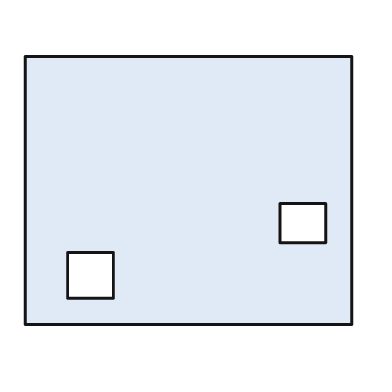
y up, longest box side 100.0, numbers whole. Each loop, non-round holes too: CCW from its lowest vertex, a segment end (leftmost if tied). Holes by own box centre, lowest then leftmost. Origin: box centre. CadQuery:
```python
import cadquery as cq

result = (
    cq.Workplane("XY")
    .moveTo(-50.0, -41.0)
    .lineTo(50.0, -41.0)
    .lineTo(50.0, 41.0)
    .lineTo(-50.0, 41.0)
    .close()
    .moveTo(-37.0, -33.0)
    .lineTo(-23.0, -33.0)
    .lineTo(-23.0, -19.0)
    .lineTo(-37.0, -19.0)
    .close()
    .moveTo(28.0, -16.0)
    .lineTo(42.0, -16.0)
    .lineTo(42.0, -4.0)
    .lineTo(28.0, -4.0)
    .close()
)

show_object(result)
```